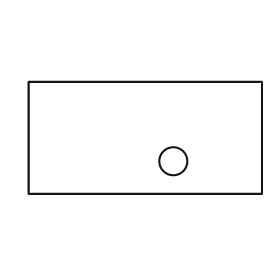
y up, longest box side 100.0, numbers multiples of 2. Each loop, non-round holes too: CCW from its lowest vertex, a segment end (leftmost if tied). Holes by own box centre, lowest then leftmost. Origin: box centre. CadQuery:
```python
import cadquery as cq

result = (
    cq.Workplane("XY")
    .moveTo(-50.0, -24.0)
    .lineTo(50.0, -24.0)
    .lineTo(50.0, 24.0)
    .lineTo(-50.0, 24.0)
    .close()
    .moveTo(12.0, -10.0)
    .circle(6.0)
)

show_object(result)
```